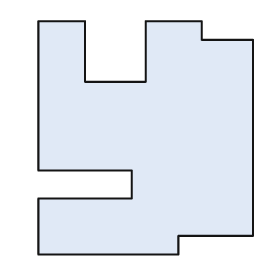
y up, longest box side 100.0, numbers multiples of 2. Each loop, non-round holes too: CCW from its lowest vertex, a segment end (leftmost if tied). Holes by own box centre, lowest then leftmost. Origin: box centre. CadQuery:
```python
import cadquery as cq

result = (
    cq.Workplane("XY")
    .moveTo(-46.0, -50.0)
    .lineTo(14.0, -50.0)
    .lineTo(14.0, -42.0)
    .lineTo(46.0, -42.0)
    .lineTo(46.0, 42.0)
    .lineTo(24.0, 42.0)
    .lineTo(24.0, 50.0)
    .lineTo(0.0, 50.0)
    .lineTo(0.0, 24.0)
    .lineTo(-26.0, 24.0)
    .lineTo(-26.0, 50.0)
    .lineTo(-46.0, 50.0)
    .lineTo(-46.0, -14.0)
    .lineTo(-6.0, -14.0)
    .lineTo(-6.0, -26.0)
    .lineTo(-46.0, -26.0)
    .close()
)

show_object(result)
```